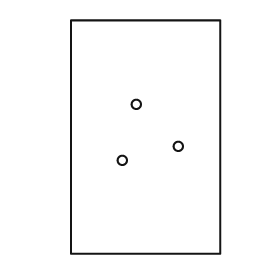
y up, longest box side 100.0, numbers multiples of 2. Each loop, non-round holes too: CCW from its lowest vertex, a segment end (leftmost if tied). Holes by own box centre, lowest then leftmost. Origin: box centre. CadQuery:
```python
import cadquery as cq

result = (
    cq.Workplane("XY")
    .moveTo(-32.0, -50.0)
    .lineTo(32.0, -50.0)
    .lineTo(32.0, 50.0)
    .lineTo(-32.0, 50.0)
    .close()
    .moveTo(-10.0, -10.0)
    .circle(2.0)
    .moveTo(14.0, -4.0)
    .circle(2.0)
    .moveTo(-4.0, 14.0)
    .circle(2.0)
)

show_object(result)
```